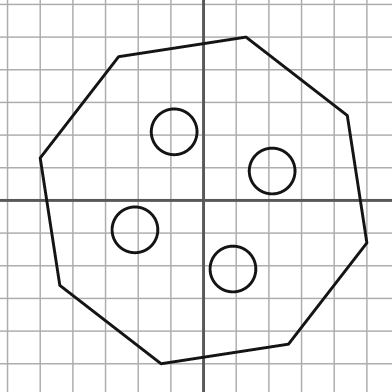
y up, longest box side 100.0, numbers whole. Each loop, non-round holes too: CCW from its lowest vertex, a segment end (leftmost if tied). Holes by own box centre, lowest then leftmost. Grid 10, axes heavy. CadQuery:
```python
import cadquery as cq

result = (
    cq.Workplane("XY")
    .moveTo(-13.0, -50.0)
    .lineTo(26.0, -44.0)
    .lineTo(50.0, -13.0)
    .lineTo(44.0, 26.0)
    .lineTo(13.0, 50.0)
    .lineTo(-26.0, 44.0)
    .lineTo(-50.0, 13.0)
    .lineTo(-44.0, -26.0)
    .close()
    .moveTo(9.0, -21.0)
    .circle(7.0)
    .moveTo(-21.0, -9.0)
    .circle(7.0)
    .moveTo(21.0, 9.0)
    .circle(7.0)
    .moveTo(-9.0, 21.0)
    .circle(7.0)
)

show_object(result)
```